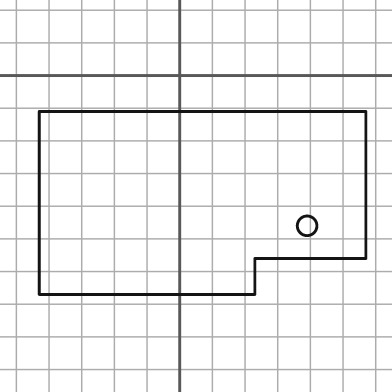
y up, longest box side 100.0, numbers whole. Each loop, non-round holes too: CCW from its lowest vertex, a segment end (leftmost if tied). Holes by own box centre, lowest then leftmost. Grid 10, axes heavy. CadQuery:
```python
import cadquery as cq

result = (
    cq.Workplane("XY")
    .moveTo(-43.0, -67.0)
    .lineTo(23.0, -67.0)
    .lineTo(23.0, -56.0)
    .lineTo(57.0, -56.0)
    .lineTo(57.0, -11.0)
    .lineTo(-43.0, -11.0)
    .close()
    .moveTo(39.0, -46.0)
    .circle(3.0)
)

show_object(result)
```